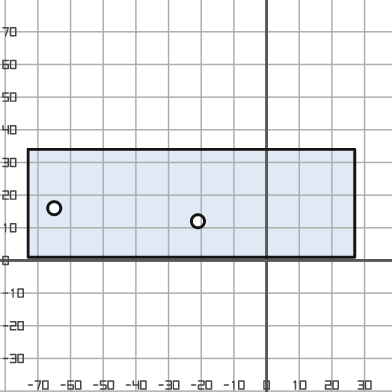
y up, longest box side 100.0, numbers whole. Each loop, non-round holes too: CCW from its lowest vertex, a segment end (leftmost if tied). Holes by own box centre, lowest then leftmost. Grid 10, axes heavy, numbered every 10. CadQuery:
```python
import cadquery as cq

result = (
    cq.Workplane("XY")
    .moveTo(-73.0, 1.0)
    .lineTo(27.0, 1.0)
    .lineTo(27.0, 34.0)
    .lineTo(-73.0, 34.0)
    .close()
    .moveTo(-21.0, 12.0)
    .circle(2.0)
    .moveTo(-65.0, 16.0)
    .circle(2.0)
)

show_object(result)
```